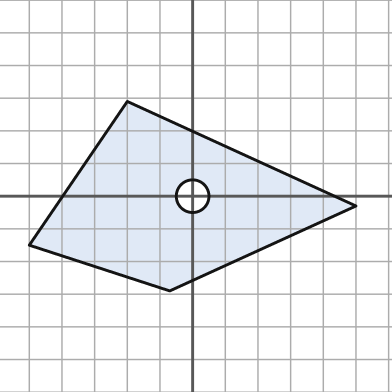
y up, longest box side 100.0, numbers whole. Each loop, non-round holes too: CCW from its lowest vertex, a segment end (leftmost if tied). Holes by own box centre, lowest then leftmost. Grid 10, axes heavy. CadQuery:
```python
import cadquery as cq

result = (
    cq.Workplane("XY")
    .moveTo(-7.0, -29.0)
    .lineTo(50.0, -3.0)
    .lineTo(-20.0, 29.0)
    .lineTo(-50.0, -15.0)
    .close()
    .moveTo(0.0, 0.0)
    .circle(5.0)
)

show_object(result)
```